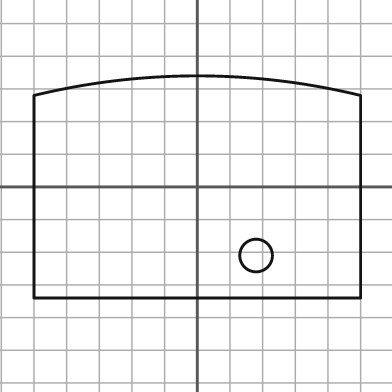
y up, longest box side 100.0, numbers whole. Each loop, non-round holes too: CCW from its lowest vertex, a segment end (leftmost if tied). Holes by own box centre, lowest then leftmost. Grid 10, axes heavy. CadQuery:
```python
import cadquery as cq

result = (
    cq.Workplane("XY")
    .moveTo(-50.0, -34.0)
    .lineTo(50.0, -34.0)
    .lineTo(50.0, 28.0)
    .threePointArc((0.0, 34.0), (-50.0, 28.0))
    .close()
    .moveTo(18.0, -21.0)
    .circle(5.0)
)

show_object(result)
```